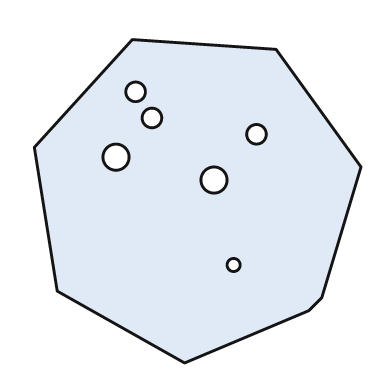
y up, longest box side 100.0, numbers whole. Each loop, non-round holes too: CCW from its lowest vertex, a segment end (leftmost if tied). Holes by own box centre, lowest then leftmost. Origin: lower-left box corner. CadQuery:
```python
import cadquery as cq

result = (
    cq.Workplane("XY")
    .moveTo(46.0, 0.0)
    .lineTo(84.0, 16.0)
    .lineTo(88.0, 20.0)
    .lineTo(100.0, 60.0)
    .lineTo(74.0, 96.0)
    .lineTo(30.0, 99.0)
    .lineTo(0.0, 66.0)
    .lineTo(7.0, 22.0)
    .close()
    .moveTo(61.0, 30.0)
    .circle(2.0)
    .moveTo(55.0, 56.0)
    .circle(4.0)
    .moveTo(25.0, 63.0)
    .circle(4.0)
    .moveTo(68.0, 70.0)
    .circle(3.0)
    .moveTo(36.0, 75.0)
    .circle(3.0)
    .moveTo(31.0, 83.0)
    .circle(3.0)
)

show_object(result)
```